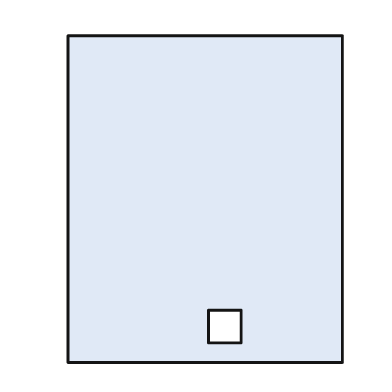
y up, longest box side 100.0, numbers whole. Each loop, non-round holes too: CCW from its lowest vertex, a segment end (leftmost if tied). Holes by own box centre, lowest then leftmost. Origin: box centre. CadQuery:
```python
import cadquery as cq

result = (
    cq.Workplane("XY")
    .moveTo(-42.0, -50.0)
    .lineTo(42.0, -50.0)
    .lineTo(42.0, 50.0)
    .lineTo(-42.0, 50.0)
    .close()
    .moveTo(1.0, -44.0)
    .lineTo(11.0, -44.0)
    .lineTo(11.0, -34.0)
    .lineTo(1.0, -34.0)
    .close()
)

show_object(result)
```